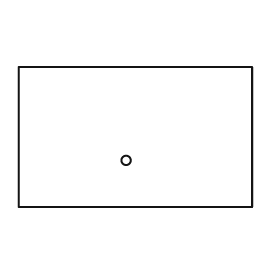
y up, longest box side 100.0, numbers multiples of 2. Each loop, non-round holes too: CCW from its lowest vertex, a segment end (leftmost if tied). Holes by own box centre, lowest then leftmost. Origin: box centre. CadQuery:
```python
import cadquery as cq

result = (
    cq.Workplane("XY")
    .moveTo(-50.0, -30.0)
    .lineTo(50.0, -30.0)
    .lineTo(50.0, 30.0)
    .lineTo(-50.0, 30.0)
    .close()
    .moveTo(-4.0, -10.0)
    .circle(2.0)
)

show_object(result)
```